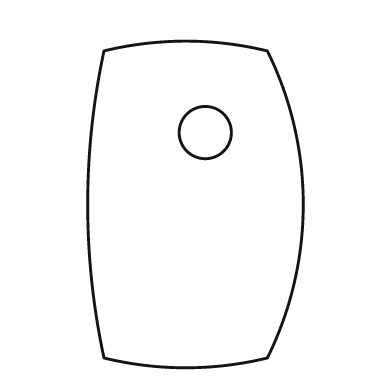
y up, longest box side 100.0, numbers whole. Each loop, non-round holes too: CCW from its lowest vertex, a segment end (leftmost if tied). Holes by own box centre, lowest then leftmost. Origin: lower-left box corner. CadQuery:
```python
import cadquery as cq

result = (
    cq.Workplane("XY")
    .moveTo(5.0, 3.0)
    .threePointArc((30.0, 0.0), (55.0, 3.0))
    .threePointArc((66.0, 50.0), (55.0, 97.0))
    .threePointArc((30.0, 100.0), (5.0, 97.0))
    .threePointArc((0.0, 50.0), (5.0, 3.0))
    .close()
    .moveTo(36.0, 72.0)
    .circle(8.0)
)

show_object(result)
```